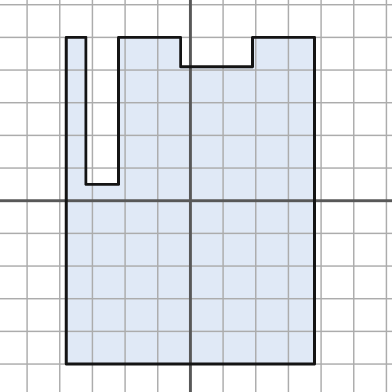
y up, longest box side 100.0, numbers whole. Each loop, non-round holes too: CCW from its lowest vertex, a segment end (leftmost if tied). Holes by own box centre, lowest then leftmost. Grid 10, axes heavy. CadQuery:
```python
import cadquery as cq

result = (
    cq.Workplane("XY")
    .moveTo(-38.0, -50.0)
    .lineTo(38.0, -50.0)
    .lineTo(38.0, 50.0)
    .lineTo(19.0, 50.0)
    .lineTo(19.0, 41.0)
    .lineTo(-3.0, 41.0)
    .lineTo(-3.0, 50.0)
    .lineTo(-22.0, 50.0)
    .lineTo(-22.0, 5.0)
    .lineTo(-32.0, 5.0)
    .lineTo(-32.0, 50.0)
    .lineTo(-38.0, 50.0)
    .close()
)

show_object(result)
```